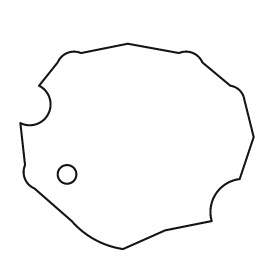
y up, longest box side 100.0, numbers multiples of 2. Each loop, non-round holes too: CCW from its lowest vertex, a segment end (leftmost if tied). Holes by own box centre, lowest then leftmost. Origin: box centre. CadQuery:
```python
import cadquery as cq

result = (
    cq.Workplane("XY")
    .moveTo(-6.0, -44.0)
    .lineTo(12.0, -36.0)
    .lineTo(32.0, -32.0)
    .threePointArc((34.0, -20.0), (44.0, -14.0))
    .lineTo(50.0, 4.0)
    .lineTo(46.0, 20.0)
    .threePointArc((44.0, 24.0), (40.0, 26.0))
    .lineTo(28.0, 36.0)
    .threePointArc((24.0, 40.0), (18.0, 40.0))
    .lineTo(-4.0, 44.0)
    .lineTo(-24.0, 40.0)
    .threePointArc((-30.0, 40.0), (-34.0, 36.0))
    .lineTo(-42.0, 26.0)
    .threePointArc((-38.0, 14.0), (-50.0, 10.0))
    .lineTo(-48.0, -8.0)
    .threePointArc((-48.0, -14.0), (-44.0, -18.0))
    .lineTo(-28.0, -32.0)
    .threePointArc((-18.0, -40.0), (-6.0, -44.0))
    .close()
    .moveTo(-30.0, -12.0)
    .circle(4.0)
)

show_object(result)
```